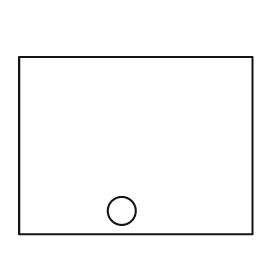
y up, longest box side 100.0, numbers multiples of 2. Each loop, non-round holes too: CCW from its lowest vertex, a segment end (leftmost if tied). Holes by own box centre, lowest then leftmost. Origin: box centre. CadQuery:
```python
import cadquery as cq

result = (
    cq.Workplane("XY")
    .moveTo(-50.0, -38.0)
    .lineTo(50.0, -38.0)
    .lineTo(50.0, 38.0)
    .lineTo(-50.0, 38.0)
    .close()
    .moveTo(-6.0, -28.0)
    .circle(6.0)
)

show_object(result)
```